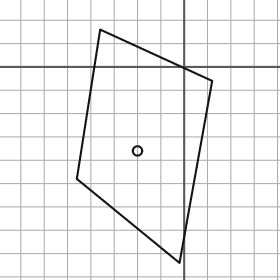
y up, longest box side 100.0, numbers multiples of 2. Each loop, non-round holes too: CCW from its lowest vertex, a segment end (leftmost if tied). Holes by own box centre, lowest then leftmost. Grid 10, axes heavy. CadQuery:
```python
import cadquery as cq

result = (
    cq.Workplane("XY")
    .moveTo(-2.0, -84.0)
    .lineTo(12.0, -6.0)
    .lineTo(-36.0, 16.0)
    .lineTo(-46.0, -48.0)
    .close()
    .moveTo(-20.0, -36.0)
    .circle(2.0)
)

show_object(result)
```